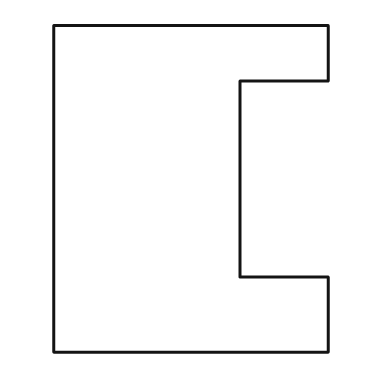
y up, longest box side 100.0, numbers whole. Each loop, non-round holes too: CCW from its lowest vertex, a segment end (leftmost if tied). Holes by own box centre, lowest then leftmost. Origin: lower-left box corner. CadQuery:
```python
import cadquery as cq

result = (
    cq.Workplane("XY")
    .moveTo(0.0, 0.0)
    .lineTo(84.0, 0.0)
    .lineTo(84.0, 23.0)
    .lineTo(57.0, 23.0)
    .lineTo(57.0, 83.0)
    .lineTo(84.0, 83.0)
    .lineTo(84.0, 100.0)
    .lineTo(0.0, 100.0)
    .close()
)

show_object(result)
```